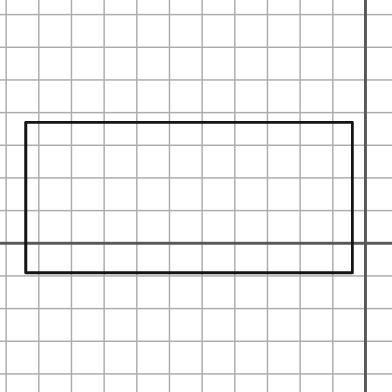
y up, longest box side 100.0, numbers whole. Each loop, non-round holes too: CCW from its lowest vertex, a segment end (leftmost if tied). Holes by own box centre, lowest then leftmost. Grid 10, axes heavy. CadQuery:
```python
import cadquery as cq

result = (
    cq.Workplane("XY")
    .moveTo(-104.0, -9.0)
    .lineTo(-4.0, -9.0)
    .lineTo(-4.0, 37.0)
    .lineTo(-104.0, 37.0)
    .close()
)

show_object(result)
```